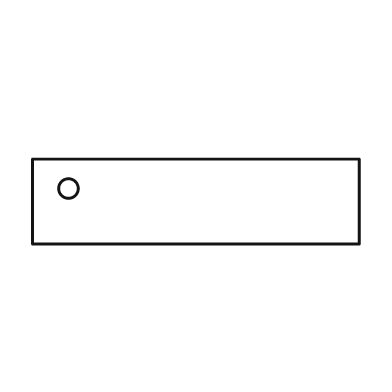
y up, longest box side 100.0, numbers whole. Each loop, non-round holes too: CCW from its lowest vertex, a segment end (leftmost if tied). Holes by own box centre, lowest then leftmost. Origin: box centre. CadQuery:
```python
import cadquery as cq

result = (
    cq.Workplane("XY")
    .moveTo(-50.0, -13.0)
    .lineTo(50.0, -13.0)
    .lineTo(50.0, 13.0)
    .lineTo(-50.0, 13.0)
    .close()
    .moveTo(-39.0, 4.0)
    .circle(3.0)
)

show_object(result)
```